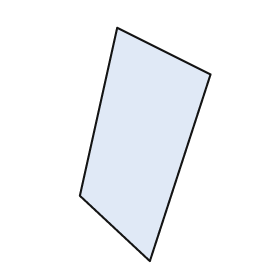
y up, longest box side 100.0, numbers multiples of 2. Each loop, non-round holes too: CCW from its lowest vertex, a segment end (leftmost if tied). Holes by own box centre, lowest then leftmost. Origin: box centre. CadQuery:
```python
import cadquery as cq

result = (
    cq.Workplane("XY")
    .moveTo(2.0, -50.0)
    .lineTo(28.0, 30.0)
    .lineTo(-12.0, 50.0)
    .lineTo(-28.0, -22.0)
    .close()
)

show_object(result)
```